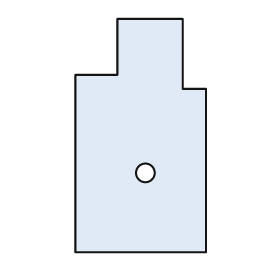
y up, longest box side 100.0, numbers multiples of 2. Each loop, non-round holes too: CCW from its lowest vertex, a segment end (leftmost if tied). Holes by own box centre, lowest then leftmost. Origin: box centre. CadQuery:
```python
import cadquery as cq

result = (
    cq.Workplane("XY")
    .moveTo(-28.0, -50.0)
    .lineTo(28.0, -50.0)
    .lineTo(28.0, 20.0)
    .lineTo(18.0, 20.0)
    .lineTo(18.0, 50.0)
    .lineTo(-10.0, 50.0)
    .lineTo(-10.0, 26.0)
    .lineTo(-28.0, 26.0)
    .close()
    .moveTo(2.0, -16.0)
    .circle(4.0)
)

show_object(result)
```